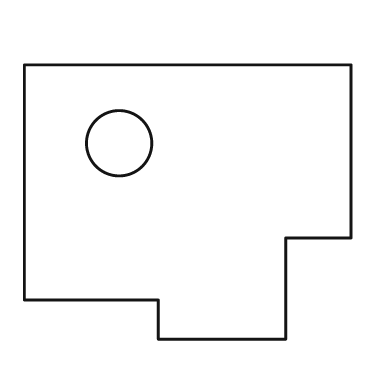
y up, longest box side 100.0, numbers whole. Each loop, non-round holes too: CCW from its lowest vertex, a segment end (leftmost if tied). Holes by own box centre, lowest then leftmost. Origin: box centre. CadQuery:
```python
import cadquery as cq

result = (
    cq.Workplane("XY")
    .moveTo(-9.0, -42.0)
    .lineTo(30.0, -42.0)
    .lineTo(30.0, -11.0)
    .lineTo(50.0, -11.0)
    .lineTo(50.0, 42.0)
    .lineTo(-50.0, 42.0)
    .lineTo(-50.0, -30.0)
    .lineTo(-9.0, -30.0)
    .close()
    .moveTo(-21.0, 18.0)
    .circle(10.0)
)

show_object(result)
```